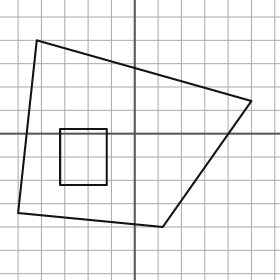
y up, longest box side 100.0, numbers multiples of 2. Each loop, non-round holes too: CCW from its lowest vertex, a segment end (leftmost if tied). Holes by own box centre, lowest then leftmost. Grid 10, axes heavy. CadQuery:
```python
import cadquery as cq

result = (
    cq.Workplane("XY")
    .moveTo(12.0, -40.0)
    .lineTo(50.0, 14.0)
    .lineTo(-42.0, 40.0)
    .lineTo(-50.0, -34.0)
    .close()
    .moveTo(-32.0, -22.0)
    .lineTo(-12.0, -22.0)
    .lineTo(-12.0, 2.0)
    .lineTo(-32.0, 2.0)
    .close()
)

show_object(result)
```